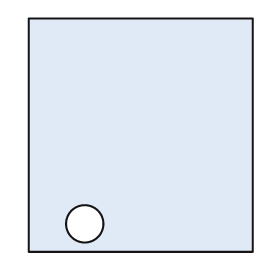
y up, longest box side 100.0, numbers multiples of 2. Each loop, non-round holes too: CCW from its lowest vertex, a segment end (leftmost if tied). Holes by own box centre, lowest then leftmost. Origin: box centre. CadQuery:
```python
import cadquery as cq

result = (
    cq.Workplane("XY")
    .moveTo(-48.0, -50.0)
    .lineTo(48.0, -50.0)
    .lineTo(48.0, 50.0)
    .lineTo(-48.0, 50.0)
    .close()
    .moveTo(-24.0, -38.0)
    .circle(8.0)
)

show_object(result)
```